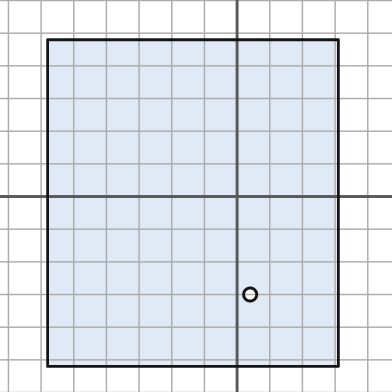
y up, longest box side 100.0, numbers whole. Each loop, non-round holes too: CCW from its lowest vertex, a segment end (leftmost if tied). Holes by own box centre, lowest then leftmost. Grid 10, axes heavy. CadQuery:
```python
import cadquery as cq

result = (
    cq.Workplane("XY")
    .moveTo(-58.0, -52.0)
    .lineTo(31.0, -52.0)
    .lineTo(31.0, 48.0)
    .lineTo(-58.0, 48.0)
    .close()
    .moveTo(4.0, -30.0)
    .circle(2.0)
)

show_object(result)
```